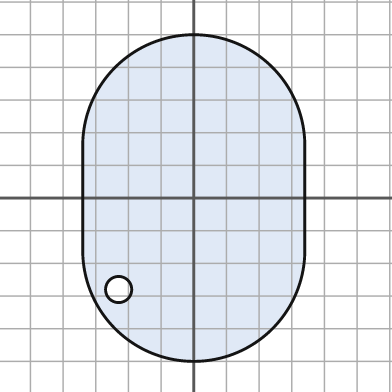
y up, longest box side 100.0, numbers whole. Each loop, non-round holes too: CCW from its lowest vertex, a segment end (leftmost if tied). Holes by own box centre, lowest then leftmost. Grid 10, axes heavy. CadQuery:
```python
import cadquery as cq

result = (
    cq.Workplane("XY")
    .moveTo(-34.0, -16.0)
    .threePointArc((0.0, -50.0), (34.0, -16.0))
    .lineTo(34.0, 16.0)
    .threePointArc((0.0, 50.0), (-34.0, 16.0))
    .close()
    .moveTo(-23.0, -28.0)
    .circle(4.0)
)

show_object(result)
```